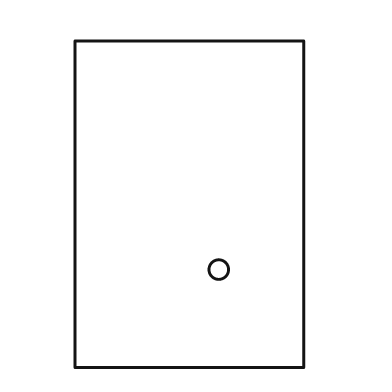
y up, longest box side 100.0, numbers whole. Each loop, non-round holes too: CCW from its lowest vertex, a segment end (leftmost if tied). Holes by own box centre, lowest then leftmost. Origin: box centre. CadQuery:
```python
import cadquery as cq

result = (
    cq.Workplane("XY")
    .moveTo(-35.0, -50.0)
    .lineTo(35.0, -50.0)
    .lineTo(35.0, 50.0)
    .lineTo(-35.0, 50.0)
    .close()
    .moveTo(9.0, -20.0)
    .circle(3.0)
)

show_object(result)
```